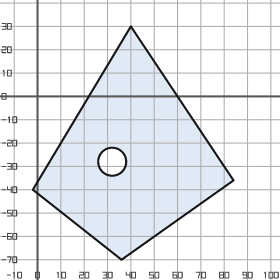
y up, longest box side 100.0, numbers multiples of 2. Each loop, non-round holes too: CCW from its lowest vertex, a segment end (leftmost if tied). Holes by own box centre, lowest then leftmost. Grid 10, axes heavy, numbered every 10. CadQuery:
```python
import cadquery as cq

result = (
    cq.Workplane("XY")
    .moveTo(36.0, -70.0)
    .lineTo(84.0, -36.0)
    .lineTo(40.0, 30.0)
    .lineTo(-2.0, -40.0)
    .close()
    .moveTo(32.0, -28.0)
    .circle(6.0)
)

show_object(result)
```